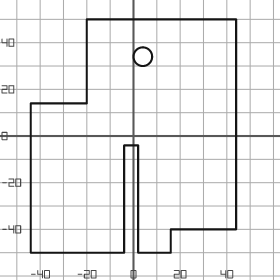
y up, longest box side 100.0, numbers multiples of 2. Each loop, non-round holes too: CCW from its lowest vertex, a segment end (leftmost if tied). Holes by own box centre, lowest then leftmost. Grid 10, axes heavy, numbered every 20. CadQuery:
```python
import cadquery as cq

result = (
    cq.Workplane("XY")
    .moveTo(-44.0, -50.0)
    .lineTo(-4.0, -50.0)
    .lineTo(-4.0, -4.0)
    .lineTo(2.0, -4.0)
    .lineTo(2.0, -50.0)
    .lineTo(16.0, -50.0)
    .lineTo(16.0, -40.0)
    .lineTo(44.0, -40.0)
    .lineTo(44.0, 50.0)
    .lineTo(-20.0, 50.0)
    .lineTo(-20.0, 14.0)
    .lineTo(-44.0, 14.0)
    .close()
    .moveTo(4.0, 34.0)
    .circle(4.0)
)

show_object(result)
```